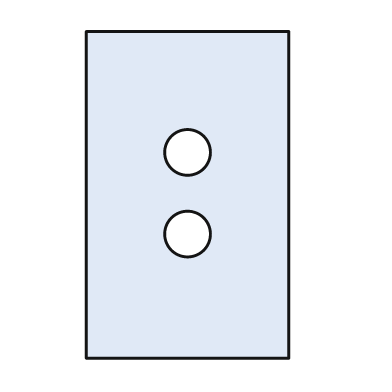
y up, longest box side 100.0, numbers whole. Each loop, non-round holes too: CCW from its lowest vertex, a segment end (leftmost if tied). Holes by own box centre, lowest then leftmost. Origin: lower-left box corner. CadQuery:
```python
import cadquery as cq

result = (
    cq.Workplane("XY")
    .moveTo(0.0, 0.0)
    .lineTo(62.0, 0.0)
    .lineTo(62.0, 100.0)
    .lineTo(0.0, 100.0)
    .close()
    .moveTo(31.0, 38.0)
    .circle(7.0)
    .moveTo(31.0, 63.0)
    .circle(7.0)
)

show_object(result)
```